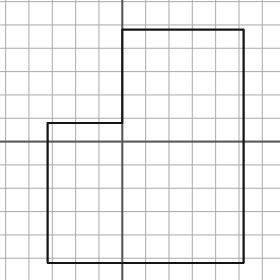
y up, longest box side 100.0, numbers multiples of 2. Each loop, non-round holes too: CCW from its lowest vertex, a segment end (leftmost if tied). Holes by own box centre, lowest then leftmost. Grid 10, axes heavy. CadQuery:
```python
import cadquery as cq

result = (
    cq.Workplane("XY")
    .moveTo(-32.0, -52.0)
    .lineTo(52.0, -52.0)
    .lineTo(52.0, 48.0)
    .lineTo(0.0, 48.0)
    .lineTo(0.0, 8.0)
    .lineTo(-32.0, 8.0)
    .close()
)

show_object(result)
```